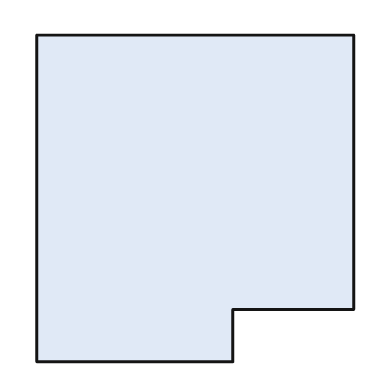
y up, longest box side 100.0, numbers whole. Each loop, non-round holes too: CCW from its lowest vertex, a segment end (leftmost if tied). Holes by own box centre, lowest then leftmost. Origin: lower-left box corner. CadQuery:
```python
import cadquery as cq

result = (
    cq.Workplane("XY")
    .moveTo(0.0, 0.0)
    .lineTo(60.0, 0.0)
    .lineTo(60.0, 16.0)
    .lineTo(97.0, 16.0)
    .lineTo(97.0, 100.0)
    .lineTo(0.0, 100.0)
    .close()
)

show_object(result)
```